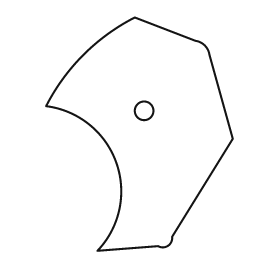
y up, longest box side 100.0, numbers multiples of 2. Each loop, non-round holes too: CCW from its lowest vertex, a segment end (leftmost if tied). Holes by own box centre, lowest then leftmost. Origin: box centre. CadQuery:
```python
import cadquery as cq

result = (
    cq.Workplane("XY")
    .moveTo(-18.0, -50.0)
    .lineTo(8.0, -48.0)
    .threePointArc((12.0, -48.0), (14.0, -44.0))
    .lineTo(40.0, -2.0)
    .lineTo(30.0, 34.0)
    .threePointArc((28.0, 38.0), (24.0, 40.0))
    .lineTo(-2.0, 50.0)
    .threePointArc((-24.0, 34.0), (-40.0, 12.0))
    .threePointArc((-10.0, -12.0), (-18.0, -50.0))
    .close()
    .moveTo(2.0, 10.0)
    .circle(4.0)
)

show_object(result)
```